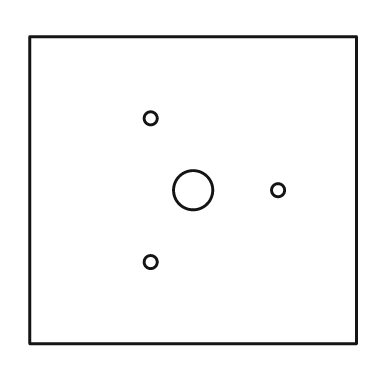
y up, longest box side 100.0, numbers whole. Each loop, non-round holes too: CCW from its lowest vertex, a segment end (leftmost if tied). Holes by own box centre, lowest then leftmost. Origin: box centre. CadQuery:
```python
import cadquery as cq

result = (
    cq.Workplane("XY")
    .moveTo(-50.0, -47.0)
    .lineTo(50.0, -47.0)
    .lineTo(50.0, 47.0)
    .lineTo(-50.0, 47.0)
    .close()
    .moveTo(-13.0, -22.0)
    .circle(2.0)
    .moveTo(0.0, 0.0)
    .circle(6.0)
    .moveTo(26.0, 0.0)
    .circle(2.0)
    .moveTo(-13.0, 22.0)
    .circle(2.0)
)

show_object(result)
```